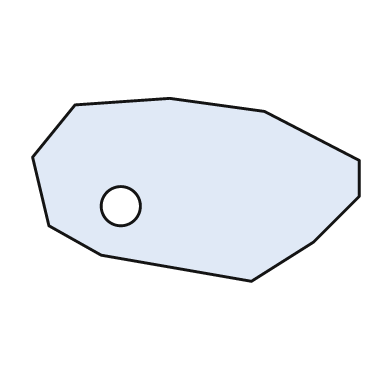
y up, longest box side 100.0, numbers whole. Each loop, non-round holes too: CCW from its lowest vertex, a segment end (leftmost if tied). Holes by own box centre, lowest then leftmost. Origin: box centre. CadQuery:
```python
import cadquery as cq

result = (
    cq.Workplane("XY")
    .moveTo(17.0, -28.0)
    .lineTo(36.0, -16.0)
    .lineTo(50.0, -2.0)
    .lineTo(50.0, 9.0)
    .lineTo(21.0, 24.0)
    .lineTo(-8.0, 28.0)
    .lineTo(-37.0, 26.0)
    .lineTo(-50.0, 10.0)
    .lineTo(-45.0, -11.0)
    .lineTo(-29.0, -20.0)
    .close()
    .moveTo(-23.0, -5.0)
    .circle(6.0)
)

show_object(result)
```